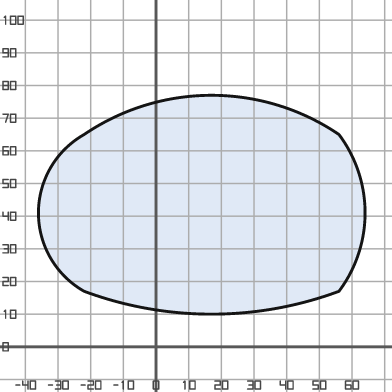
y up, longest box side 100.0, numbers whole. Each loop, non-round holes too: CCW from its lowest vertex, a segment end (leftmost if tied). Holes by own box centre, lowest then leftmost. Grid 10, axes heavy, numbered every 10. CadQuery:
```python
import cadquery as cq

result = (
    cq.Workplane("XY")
    .moveTo(-22.0, 17.0)
    .threePointArc((17.0, 10.0), (56.0, 17.0))
    .threePointArc((64.0, 41.0), (56.0, 65.0))
    .threePointArc((17.0, 77.0), (-22.0, 65.0))
    .threePointArc((-36.0, 41.0), (-22.0, 17.0))
    .close()
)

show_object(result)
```